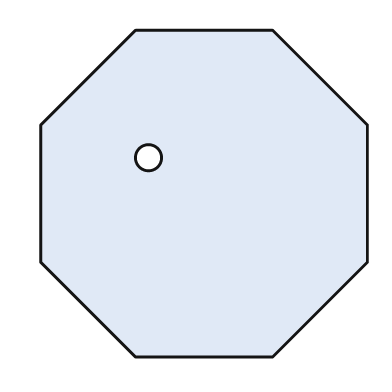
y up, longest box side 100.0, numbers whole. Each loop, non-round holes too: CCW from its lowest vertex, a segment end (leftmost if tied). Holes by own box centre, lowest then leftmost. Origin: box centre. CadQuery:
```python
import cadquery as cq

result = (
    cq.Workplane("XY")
    .moveTo(-21.0, -50.0)
    .lineTo(21.0, -50.0)
    .lineTo(50.0, -21.0)
    .lineTo(50.0, 21.0)
    .lineTo(21.0, 50.0)
    .lineTo(-21.0, 50.0)
    .lineTo(-50.0, 21.0)
    .lineTo(-50.0, -21.0)
    .close()
    .moveTo(-17.0, 11.0)
    .circle(4.0)
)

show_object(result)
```